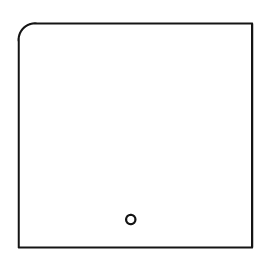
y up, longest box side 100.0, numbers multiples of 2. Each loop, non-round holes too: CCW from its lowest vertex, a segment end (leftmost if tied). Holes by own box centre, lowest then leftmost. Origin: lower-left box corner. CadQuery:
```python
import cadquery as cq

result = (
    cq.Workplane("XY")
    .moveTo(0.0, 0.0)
    .lineTo(100.0, 0.0)
    .lineTo(100.0, 96.0)
    .lineTo(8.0, 96.0)
    .threePointArc((2.0, 94.0), (0.0, 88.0))
    .close()
    .moveTo(48.0, 12.0)
    .circle(2.0)
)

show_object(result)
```